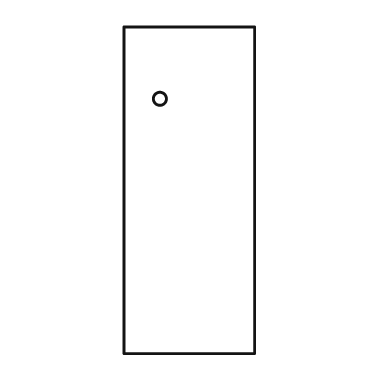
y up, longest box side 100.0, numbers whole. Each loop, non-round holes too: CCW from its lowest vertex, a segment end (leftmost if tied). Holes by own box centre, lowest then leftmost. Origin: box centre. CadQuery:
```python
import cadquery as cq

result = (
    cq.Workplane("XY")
    .moveTo(-20.0, -50.0)
    .lineTo(20.0, -50.0)
    .lineTo(20.0, 50.0)
    .lineTo(-20.0, 50.0)
    .close()
    .moveTo(-9.0, 28.0)
    .circle(2.0)
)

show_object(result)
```